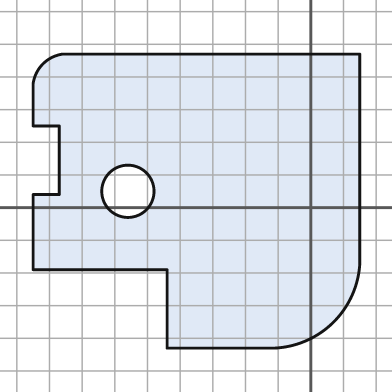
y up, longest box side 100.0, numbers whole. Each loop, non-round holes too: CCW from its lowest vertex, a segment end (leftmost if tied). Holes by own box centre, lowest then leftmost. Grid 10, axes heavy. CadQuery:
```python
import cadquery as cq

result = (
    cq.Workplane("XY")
    .moveTo(-44.0, -43.0)
    .lineTo(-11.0, -43.0)
    .threePointArc((7.0, -35.0), (15.0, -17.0))
    .lineTo(15.0, 47.0)
    .lineTo(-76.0, 47.0)
    .threePointArc((-82.0, 44.0), (-85.0, 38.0))
    .lineTo(-85.0, 25.0)
    .lineTo(-77.0, 25.0)
    .lineTo(-77.0, 4.0)
    .lineTo(-85.0, 4.0)
    .lineTo(-85.0, -19.0)
    .lineTo(-44.0, -19.0)
    .close()
    .moveTo(-56.0, 5.0)
    .circle(8.0)
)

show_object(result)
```